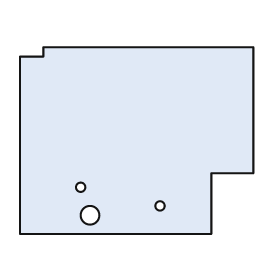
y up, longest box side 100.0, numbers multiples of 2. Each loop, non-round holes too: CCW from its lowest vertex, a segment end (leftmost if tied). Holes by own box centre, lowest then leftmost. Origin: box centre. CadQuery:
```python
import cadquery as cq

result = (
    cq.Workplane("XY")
    .moveTo(-50.0, -40.0)
    .lineTo(32.0, -40.0)
    .lineTo(32.0, -14.0)
    .lineTo(50.0, -14.0)
    .lineTo(50.0, 40.0)
    .lineTo(-40.0, 40.0)
    .lineTo(-40.0, 36.0)
    .lineTo(-50.0, 36.0)
    .close()
    .moveTo(-20.0, -32.0)
    .circle(4.0)
    .moveTo(10.0, -28.0)
    .circle(2.0)
    .moveTo(-24.0, -20.0)
    .circle(2.0)
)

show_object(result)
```